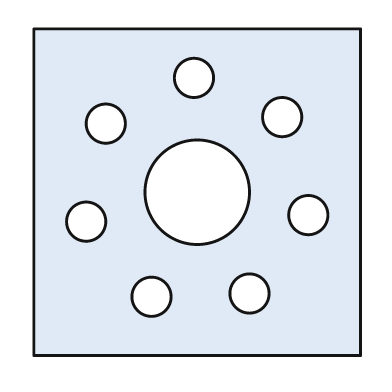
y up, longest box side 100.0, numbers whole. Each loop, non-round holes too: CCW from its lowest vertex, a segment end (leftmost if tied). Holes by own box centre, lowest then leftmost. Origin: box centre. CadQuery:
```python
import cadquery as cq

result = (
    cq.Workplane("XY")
    .moveTo(-50.0, -50.0)
    .lineTo(50.0, -50.0)
    .lineTo(50.0, 50.0)
    .lineTo(-50.0, 50.0)
    .close()
    .moveTo(-14.0, -32.0)
    .circle(6.0)
    .moveTo(16.0, -31.0)
    .circle(6.0)
    .moveTo(-34.0, -9.0)
    .circle(6.0)
    .moveTo(34.0, -7.0)
    .circle(6.0)
    .moveTo(0.0, 0.0)
    .circle(16.0)
    .moveTo(-28.0, 21.0)
    .circle(6.0)
    .moveTo(26.0, 23.0)
    .circle(6.0)
    .moveTo(-1.0, 35.0)
    .circle(6.0)
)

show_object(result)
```